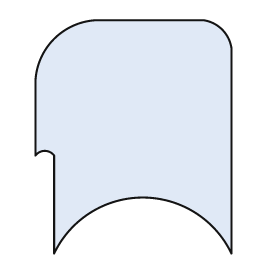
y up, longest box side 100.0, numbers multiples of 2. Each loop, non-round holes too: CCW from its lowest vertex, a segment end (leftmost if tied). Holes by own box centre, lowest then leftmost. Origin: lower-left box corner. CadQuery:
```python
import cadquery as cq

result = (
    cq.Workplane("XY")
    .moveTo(8.0, 0.0)
    .threePointArc((46.0, 24.0), (84.0, 0.0))
    .lineTo(84.0, 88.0)
    .threePointArc((80.0, 96.0), (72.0, 100.0))
    .lineTo(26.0, 100.0)
    .threePointArc((8.0, 92.0), (0.0, 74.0))
    .lineTo(0.0, 42.0)
    .threePointArc((4.0, 44.0), (8.0, 42.0))
    .close()
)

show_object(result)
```